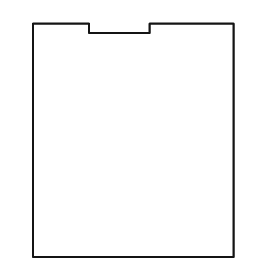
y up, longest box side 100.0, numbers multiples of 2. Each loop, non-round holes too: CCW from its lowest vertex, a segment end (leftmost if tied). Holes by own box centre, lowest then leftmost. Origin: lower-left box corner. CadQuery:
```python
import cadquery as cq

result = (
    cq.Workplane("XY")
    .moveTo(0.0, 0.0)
    .lineTo(86.0, 0.0)
    .lineTo(86.0, 100.0)
    .lineTo(50.0, 100.0)
    .lineTo(50.0, 96.0)
    .lineTo(24.0, 96.0)
    .lineTo(24.0, 100.0)
    .lineTo(0.0, 100.0)
    .close()
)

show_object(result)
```